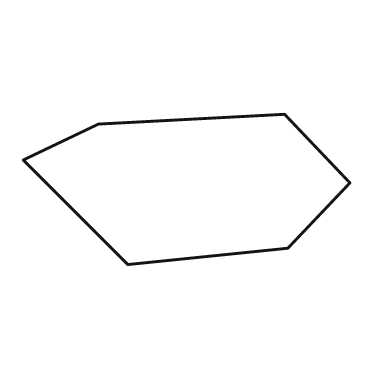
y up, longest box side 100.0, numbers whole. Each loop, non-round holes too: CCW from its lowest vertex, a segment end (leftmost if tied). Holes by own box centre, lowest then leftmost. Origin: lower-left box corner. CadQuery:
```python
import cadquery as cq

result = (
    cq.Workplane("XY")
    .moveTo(32.0, 0.0)
    .lineTo(81.0, 5.0)
    .lineTo(100.0, 25.0)
    .lineTo(80.0, 46.0)
    .lineTo(23.0, 43.0)
    .lineTo(0.0, 32.0)
    .close()
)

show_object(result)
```